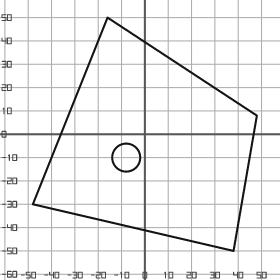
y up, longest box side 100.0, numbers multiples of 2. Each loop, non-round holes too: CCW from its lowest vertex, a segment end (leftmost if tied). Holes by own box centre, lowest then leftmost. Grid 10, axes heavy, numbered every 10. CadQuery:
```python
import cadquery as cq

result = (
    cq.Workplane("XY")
    .moveTo(38.0, -50.0)
    .lineTo(48.0, 8.0)
    .lineTo(-16.0, 50.0)
    .lineTo(-48.0, -30.0)
    .close()
    .moveTo(-8.0, -10.0)
    .circle(6.0)
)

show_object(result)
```